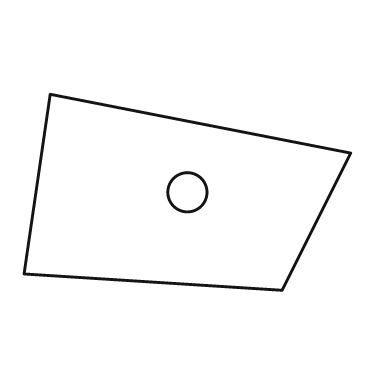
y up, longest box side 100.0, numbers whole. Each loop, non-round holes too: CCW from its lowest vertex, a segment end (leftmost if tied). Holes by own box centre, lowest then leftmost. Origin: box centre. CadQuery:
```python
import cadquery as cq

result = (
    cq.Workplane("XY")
    .moveTo(29.0, -30.0)
    .lineTo(50.0, 12.0)
    .lineTo(-42.0, 30.0)
    .lineTo(-50.0, -25.0)
    .close()
    .moveTo(0.0, 0.0)
    .circle(6.0)
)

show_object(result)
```